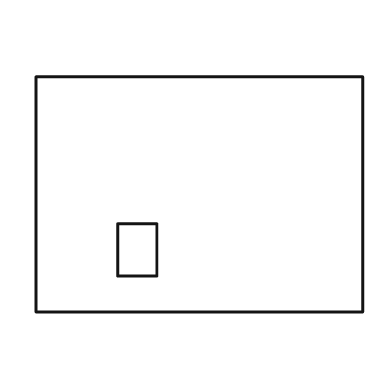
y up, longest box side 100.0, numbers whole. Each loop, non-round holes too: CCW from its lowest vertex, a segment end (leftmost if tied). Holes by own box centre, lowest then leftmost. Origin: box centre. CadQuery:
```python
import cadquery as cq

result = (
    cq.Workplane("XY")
    .moveTo(-50.0, -36.0)
    .lineTo(50.0, -36.0)
    .lineTo(50.0, 36.0)
    .lineTo(-50.0, 36.0)
    .close()
    .moveTo(-25.0, -25.0)
    .lineTo(-13.0, -25.0)
    .lineTo(-13.0, -9.0)
    .lineTo(-25.0, -9.0)
    .close()
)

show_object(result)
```